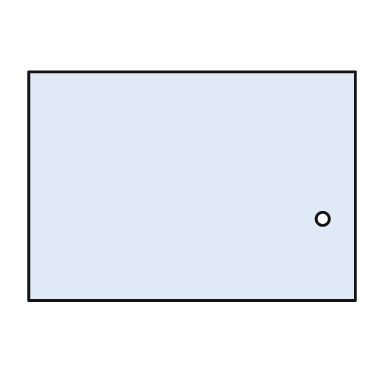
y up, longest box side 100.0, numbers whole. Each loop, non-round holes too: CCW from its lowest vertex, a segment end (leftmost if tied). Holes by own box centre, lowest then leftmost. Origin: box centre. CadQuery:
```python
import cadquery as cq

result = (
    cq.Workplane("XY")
    .moveTo(-50.0, -35.0)
    .lineTo(50.0, -35.0)
    .lineTo(50.0, 35.0)
    .lineTo(-50.0, 35.0)
    .close()
    .moveTo(40.0, -10.0)
    .circle(2.0)
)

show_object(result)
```